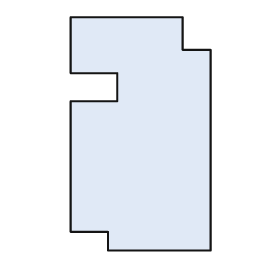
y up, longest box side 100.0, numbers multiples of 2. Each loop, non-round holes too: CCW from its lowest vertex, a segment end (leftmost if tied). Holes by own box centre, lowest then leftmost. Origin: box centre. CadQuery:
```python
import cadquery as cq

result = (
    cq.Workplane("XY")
    .moveTo(-14.0, -50.0)
    .lineTo(30.0, -50.0)
    .lineTo(30.0, 36.0)
    .lineTo(18.0, 36.0)
    .lineTo(18.0, 50.0)
    .lineTo(-30.0, 50.0)
    .lineTo(-30.0, 26.0)
    .lineTo(-10.0, 26.0)
    .lineTo(-10.0, 14.0)
    .lineTo(-30.0, 14.0)
    .lineTo(-30.0, -42.0)
    .lineTo(-14.0, -42.0)
    .close()
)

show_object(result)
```